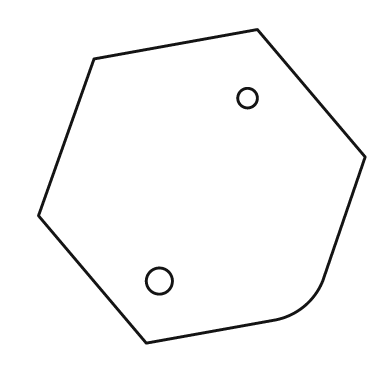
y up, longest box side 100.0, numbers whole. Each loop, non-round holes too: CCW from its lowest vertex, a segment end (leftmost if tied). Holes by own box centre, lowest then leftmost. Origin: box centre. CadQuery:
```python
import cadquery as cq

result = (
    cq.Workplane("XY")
    .moveTo(-17.0, -48.0)
    .lineTo(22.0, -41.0)
    .threePointArc((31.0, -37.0), (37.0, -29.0))
    .lineTo(50.0, 9.0)
    .lineTo(17.0, 48.0)
    .lineTo(-33.0, 39.0)
    .lineTo(-50.0, -9.0)
    .close()
    .moveTo(-13.0, -29.0)
    .circle(4.0)
    .moveTo(14.0, 27.0)
    .circle(3.0)
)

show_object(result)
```